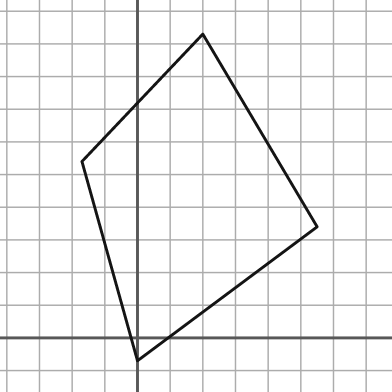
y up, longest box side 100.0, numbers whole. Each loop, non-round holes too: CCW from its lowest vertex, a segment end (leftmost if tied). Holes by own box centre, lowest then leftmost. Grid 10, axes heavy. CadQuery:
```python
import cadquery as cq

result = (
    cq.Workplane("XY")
    .moveTo(0.0, -7.0)
    .lineTo(55.0, 34.0)
    .lineTo(20.0, 93.0)
    .lineTo(-17.0, 54.0)
    .close()
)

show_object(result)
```